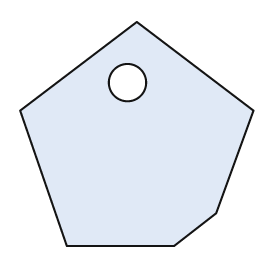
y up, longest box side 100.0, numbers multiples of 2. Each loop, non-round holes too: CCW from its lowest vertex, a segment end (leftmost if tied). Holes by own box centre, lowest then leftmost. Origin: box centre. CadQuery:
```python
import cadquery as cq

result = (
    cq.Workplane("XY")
    .moveTo(-30.0, -48.0)
    .lineTo(16.0, -48.0)
    .lineTo(34.0, -34.0)
    .lineTo(50.0, 10.0)
    .lineTo(0.0, 48.0)
    .lineTo(-50.0, 10.0)
    .close()
    .moveTo(-4.0, 22.0)
    .circle(8.0)
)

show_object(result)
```